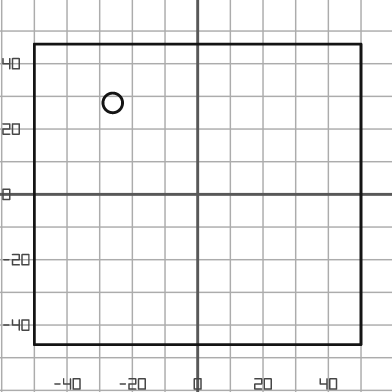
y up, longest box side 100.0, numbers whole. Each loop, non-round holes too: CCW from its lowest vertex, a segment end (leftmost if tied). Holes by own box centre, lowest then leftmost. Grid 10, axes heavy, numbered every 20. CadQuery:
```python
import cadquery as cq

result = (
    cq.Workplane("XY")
    .moveTo(-50.0, -46.0)
    .lineTo(50.0, -46.0)
    .lineTo(50.0, 46.0)
    .lineTo(-50.0, 46.0)
    .close()
    .moveTo(-26.0, 28.0)
    .circle(3.0)
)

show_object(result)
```